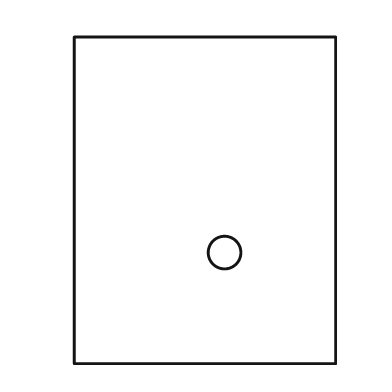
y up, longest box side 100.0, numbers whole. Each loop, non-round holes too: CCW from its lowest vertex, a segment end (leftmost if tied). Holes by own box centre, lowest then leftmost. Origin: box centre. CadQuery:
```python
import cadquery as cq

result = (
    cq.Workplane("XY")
    .moveTo(-40.0, -50.0)
    .lineTo(40.0, -50.0)
    .lineTo(40.0, 50.0)
    .lineTo(-40.0, 50.0)
    .close()
    .moveTo(6.0, -16.0)
    .circle(5.0)
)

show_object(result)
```